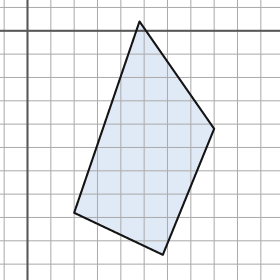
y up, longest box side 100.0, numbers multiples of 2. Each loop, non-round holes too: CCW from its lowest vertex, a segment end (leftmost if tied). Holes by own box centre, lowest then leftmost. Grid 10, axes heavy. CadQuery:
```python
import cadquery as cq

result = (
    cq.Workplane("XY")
    .moveTo(58.0, -96.0)
    .lineTo(80.0, -42.0)
    .lineTo(48.0, 4.0)
    .lineTo(20.0, -78.0)
    .close()
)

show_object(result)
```